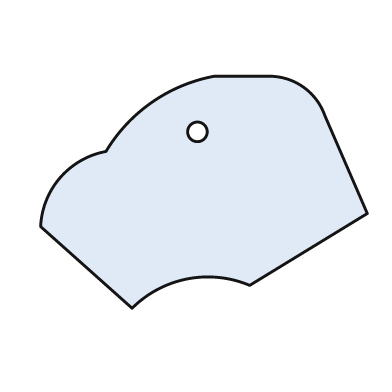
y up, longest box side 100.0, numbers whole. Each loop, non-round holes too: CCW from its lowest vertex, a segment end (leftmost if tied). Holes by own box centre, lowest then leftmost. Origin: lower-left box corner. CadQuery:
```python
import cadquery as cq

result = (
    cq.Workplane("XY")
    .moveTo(28.0, 0.0)
    .threePointArc((45.0, 9.0), (64.0, 7.0))
    .lineTo(100.0, 29.0)
    .lineTo(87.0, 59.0)
    .threePointArc((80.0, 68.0), (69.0, 71.0))
    .lineTo(53.0, 71.0)
    .threePointArc((34.0, 63.0), (20.0, 48.0))
    .threePointArc((6.0, 40.0), (0.0, 25.0))
    .close()
    .moveTo(48.0, 54.0)
    .circle(3.0)
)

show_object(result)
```